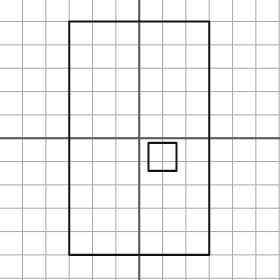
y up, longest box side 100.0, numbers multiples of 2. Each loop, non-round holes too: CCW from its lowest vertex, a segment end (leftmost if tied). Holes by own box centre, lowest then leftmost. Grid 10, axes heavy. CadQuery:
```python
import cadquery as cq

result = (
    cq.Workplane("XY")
    .moveTo(-30.0, -50.0)
    .lineTo(30.0, -50.0)
    .lineTo(30.0, 50.0)
    .lineTo(-30.0, 50.0)
    .close()
    .moveTo(4.0, -14.0)
    .lineTo(16.0, -14.0)
    .lineTo(16.0, -2.0)
    .lineTo(4.0, -2.0)
    .close()
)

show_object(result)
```